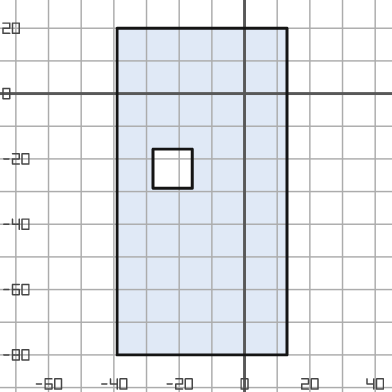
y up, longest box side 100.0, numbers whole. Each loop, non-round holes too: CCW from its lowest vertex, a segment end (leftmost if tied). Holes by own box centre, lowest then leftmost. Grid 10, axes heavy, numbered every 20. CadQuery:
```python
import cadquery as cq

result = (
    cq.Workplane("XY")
    .moveTo(-39.0, -80.0)
    .lineTo(13.0, -80.0)
    .lineTo(13.0, 20.0)
    .lineTo(-39.0, 20.0)
    .close()
    .moveTo(-28.0, -29.0)
    .lineTo(-16.0, -29.0)
    .lineTo(-16.0, -17.0)
    .lineTo(-28.0, -17.0)
    .close()
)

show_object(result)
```